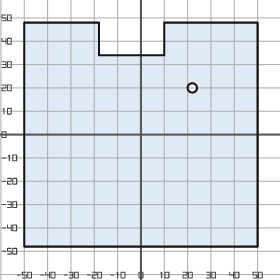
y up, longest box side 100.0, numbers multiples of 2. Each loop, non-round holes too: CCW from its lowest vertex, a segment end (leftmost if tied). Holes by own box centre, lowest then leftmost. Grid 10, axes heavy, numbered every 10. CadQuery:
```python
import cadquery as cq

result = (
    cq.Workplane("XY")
    .moveTo(-50.0, -48.0)
    .lineTo(50.0, -48.0)
    .lineTo(50.0, 48.0)
    .lineTo(10.0, 48.0)
    .lineTo(10.0, 34.0)
    .lineTo(-18.0, 34.0)
    .lineTo(-18.0, 48.0)
    .lineTo(-50.0, 48.0)
    .close()
    .moveTo(22.0, 20.0)
    .circle(2.0)
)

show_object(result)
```